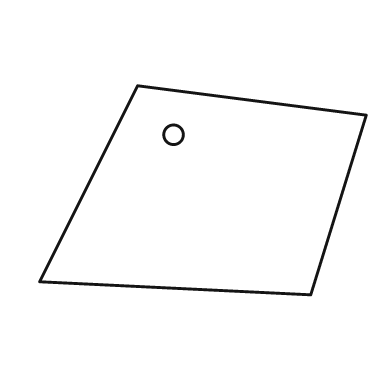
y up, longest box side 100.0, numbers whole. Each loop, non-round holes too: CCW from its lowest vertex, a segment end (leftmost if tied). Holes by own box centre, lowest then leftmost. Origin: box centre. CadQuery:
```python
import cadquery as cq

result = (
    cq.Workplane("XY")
    .moveTo(33.0, -32.0)
    .lineTo(50.0, 23.0)
    .lineTo(-20.0, 32.0)
    .lineTo(-50.0, -28.0)
    .close()
    .moveTo(-9.0, 17.0)
    .circle(3.0)
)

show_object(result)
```